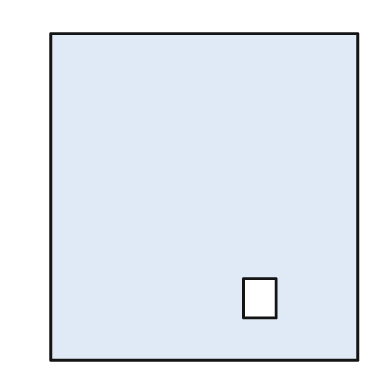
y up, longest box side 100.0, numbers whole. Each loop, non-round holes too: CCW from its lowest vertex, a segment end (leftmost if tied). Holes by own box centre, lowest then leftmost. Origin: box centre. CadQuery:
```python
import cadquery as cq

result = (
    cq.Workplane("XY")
    .moveTo(-47.0, -50.0)
    .lineTo(47.0, -50.0)
    .lineTo(47.0, 50.0)
    .lineTo(-47.0, 50.0)
    .close()
    .moveTo(12.0, -37.0)
    .lineTo(22.0, -37.0)
    .lineTo(22.0, -25.0)
    .lineTo(12.0, -25.0)
    .close()
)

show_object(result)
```